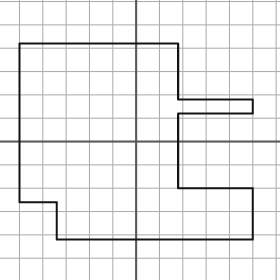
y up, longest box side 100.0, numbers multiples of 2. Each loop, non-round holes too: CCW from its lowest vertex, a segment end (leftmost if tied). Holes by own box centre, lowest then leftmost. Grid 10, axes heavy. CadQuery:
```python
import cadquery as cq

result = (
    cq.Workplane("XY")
    .moveTo(-34.0, -42.0)
    .lineTo(50.0, -42.0)
    .lineTo(50.0, -20.0)
    .lineTo(18.0, -20.0)
    .lineTo(18.0, 12.0)
    .lineTo(50.0, 12.0)
    .lineTo(50.0, 18.0)
    .lineTo(18.0, 18.0)
    .lineTo(18.0, 42.0)
    .lineTo(-50.0, 42.0)
    .lineTo(-50.0, -26.0)
    .lineTo(-34.0, -26.0)
    .close()
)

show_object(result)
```